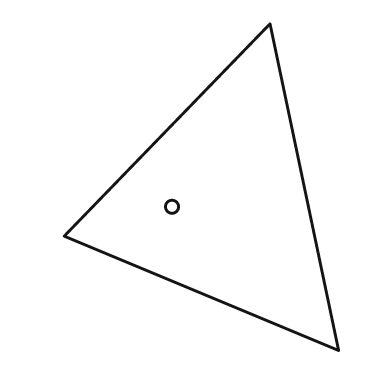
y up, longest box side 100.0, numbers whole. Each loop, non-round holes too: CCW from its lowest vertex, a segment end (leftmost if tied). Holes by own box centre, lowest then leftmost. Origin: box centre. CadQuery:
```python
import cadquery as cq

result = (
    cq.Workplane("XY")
    .moveTo(42.0, -50.0)
    .lineTo(21.0, 50.0)
    .lineTo(-42.0, -15.0)
    .close()
    .moveTo(-9.0, -6.0)
    .circle(2.0)
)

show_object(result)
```